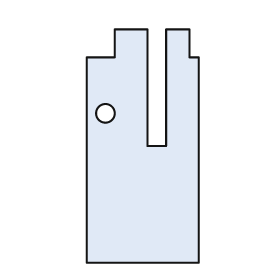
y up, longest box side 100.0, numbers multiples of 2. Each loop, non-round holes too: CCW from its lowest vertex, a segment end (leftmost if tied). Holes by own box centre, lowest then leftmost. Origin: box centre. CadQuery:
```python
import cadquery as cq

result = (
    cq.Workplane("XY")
    .moveTo(-24.0, -50.0)
    .lineTo(24.0, -50.0)
    .lineTo(24.0, 38.0)
    .lineTo(20.0, 38.0)
    .lineTo(20.0, 50.0)
    .lineTo(10.0, 50.0)
    .lineTo(10.0, 0.0)
    .lineTo(2.0, 0.0)
    .lineTo(2.0, 50.0)
    .lineTo(-12.0, 50.0)
    .lineTo(-12.0, 38.0)
    .lineTo(-24.0, 38.0)
    .close()
    .moveTo(-16.0, 14.0)
    .circle(4.0)
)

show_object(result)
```